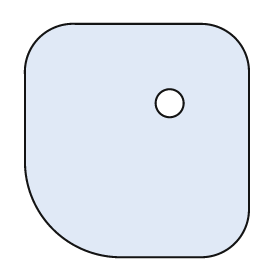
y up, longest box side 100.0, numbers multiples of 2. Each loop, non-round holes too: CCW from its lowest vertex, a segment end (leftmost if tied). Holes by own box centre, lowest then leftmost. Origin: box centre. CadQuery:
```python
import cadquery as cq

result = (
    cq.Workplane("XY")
    .moveTo(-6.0, -50.0)
    .lineTo(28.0, -50.0)
    .threePointArc((42.0, -44.0), (48.0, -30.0))
    .lineTo(48.0, 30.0)
    .threePointArc((42.0, 44.0), (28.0, 50.0))
    .lineTo(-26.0, 50.0)
    .threePointArc((-42.0, 44.0), (-48.0, 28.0))
    .lineTo(-48.0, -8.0)
    .threePointArc((-36.0, -38.0), (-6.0, -50.0))
    .close()
    .moveTo(14.0, 16.0)
    .circle(6.0)
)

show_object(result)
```